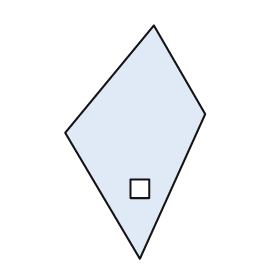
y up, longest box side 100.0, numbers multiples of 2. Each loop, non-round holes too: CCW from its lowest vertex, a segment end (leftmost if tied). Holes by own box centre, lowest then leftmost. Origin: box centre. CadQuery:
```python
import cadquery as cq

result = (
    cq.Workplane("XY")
    .moveTo(2.0, -50.0)
    .lineTo(30.0, 12.0)
    .lineTo(8.0, 50.0)
    .lineTo(-30.0, 4.0)
    .close()
    .moveTo(-2.0, -24.0)
    .lineTo(6.0, -24.0)
    .lineTo(6.0, -16.0)
    .lineTo(-2.0, -16.0)
    .close()
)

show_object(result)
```